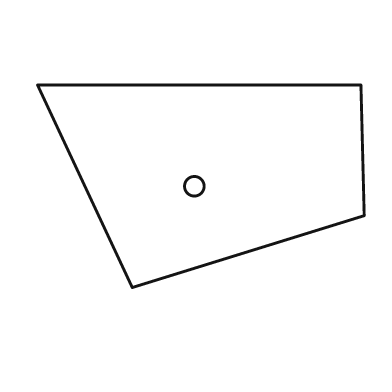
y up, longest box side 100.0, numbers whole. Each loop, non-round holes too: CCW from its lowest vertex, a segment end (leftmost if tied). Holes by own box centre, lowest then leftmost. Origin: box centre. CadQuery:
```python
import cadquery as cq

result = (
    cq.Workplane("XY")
    .moveTo(-21.0, -31.0)
    .lineTo(50.0, -9.0)
    .lineTo(49.0, 31.0)
    .lineTo(-50.0, 31.0)
    .close()
    .moveTo(-2.0, 0.0)
    .circle(3.0)
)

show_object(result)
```